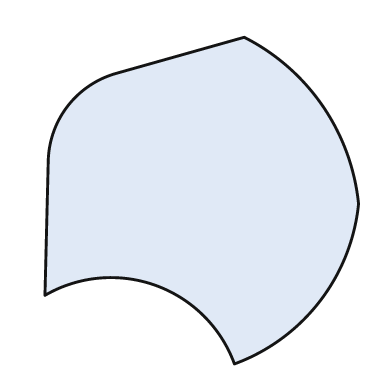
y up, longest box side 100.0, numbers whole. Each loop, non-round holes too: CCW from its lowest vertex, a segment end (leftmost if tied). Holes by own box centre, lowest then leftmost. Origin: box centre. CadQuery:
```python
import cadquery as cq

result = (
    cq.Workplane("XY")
    .moveTo(10.0, -50.0)
    .threePointArc((36.0, -31.0), (48.0, -1.0))
    .threePointArc((37.0, 29.0), (13.0, 50.0))
    .lineTo(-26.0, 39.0)
    .threePointArc((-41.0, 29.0), (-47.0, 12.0))
    .lineTo(-48.0, -29.0)
    .threePointArc((-14.0, -26.0), (10.0, -50.0))
    .close()
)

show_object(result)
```